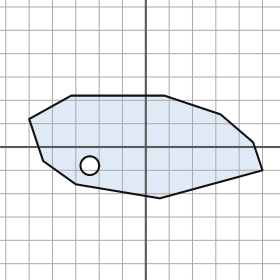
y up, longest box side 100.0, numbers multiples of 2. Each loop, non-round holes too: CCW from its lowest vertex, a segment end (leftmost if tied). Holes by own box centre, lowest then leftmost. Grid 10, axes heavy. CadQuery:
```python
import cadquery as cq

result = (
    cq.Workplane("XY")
    .moveTo(6.0, -22.0)
    .lineTo(50.0, -10.0)
    .lineTo(46.0, 2.0)
    .lineTo(32.0, 14.0)
    .lineTo(8.0, 22.0)
    .lineTo(-32.0, 22.0)
    .lineTo(-50.0, 12.0)
    .lineTo(-44.0, -6.0)
    .lineTo(-30.0, -16.0)
    .close()
    .moveTo(-24.0, -8.0)
    .circle(4.0)
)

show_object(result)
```